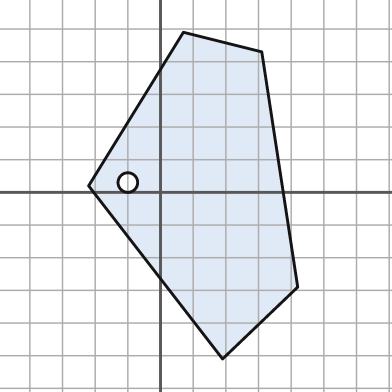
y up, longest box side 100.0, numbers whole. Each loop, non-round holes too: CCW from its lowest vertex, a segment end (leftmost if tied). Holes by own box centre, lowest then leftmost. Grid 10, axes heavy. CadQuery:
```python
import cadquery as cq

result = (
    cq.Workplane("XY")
    .moveTo(19.0, -51.0)
    .lineTo(42.0, -29.0)
    .lineTo(31.0, 43.0)
    .lineTo(7.0, 49.0)
    .lineTo(-22.0, 2.0)
    .close()
    .moveTo(-10.0, 3.0)
    .circle(3.0)
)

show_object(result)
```